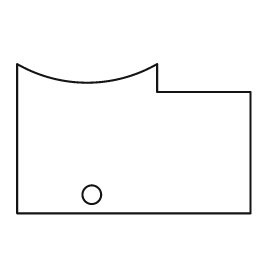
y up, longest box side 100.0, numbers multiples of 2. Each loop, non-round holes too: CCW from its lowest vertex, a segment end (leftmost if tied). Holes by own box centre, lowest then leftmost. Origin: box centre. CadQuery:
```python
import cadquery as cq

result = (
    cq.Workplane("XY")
    .moveTo(-50.0, -32.0)
    .lineTo(50.0, -32.0)
    .lineTo(50.0, 20.0)
    .lineTo(10.0, 20.0)
    .lineTo(10.0, 32.0)
    .threePointArc((-20.0, 24.0), (-50.0, 32.0))
    .close()
    .moveTo(-18.0, -24.0)
    .circle(4.0)
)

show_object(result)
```